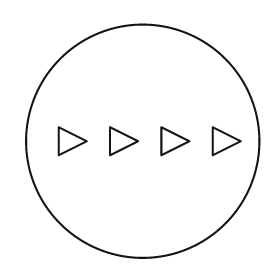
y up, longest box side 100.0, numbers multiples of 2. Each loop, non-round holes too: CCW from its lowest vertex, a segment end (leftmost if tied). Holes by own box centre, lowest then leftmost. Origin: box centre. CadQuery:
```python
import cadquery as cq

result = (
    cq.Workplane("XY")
    .moveTo(0.0, 0.0)
    .circle(50.0)
    .moveTo(-36.0, -6.0)
    .lineTo(-24.0, 0.0)
    .lineTo(-36.0, 6.0)
    .close()
    .moveTo(-14.0, -6.0)
    .lineTo(-2.0, 0.0)
    .lineTo(-14.0, 6.0)
    .close()
    .moveTo(8.0, -6.0)
    .lineTo(20.0, 0.0)
    .lineTo(8.0, 6.0)
    .close()
    .moveTo(30.0, -6.0)
    .lineTo(42.0, 0.0)
    .lineTo(30.0, 6.0)
    .close()
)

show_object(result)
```